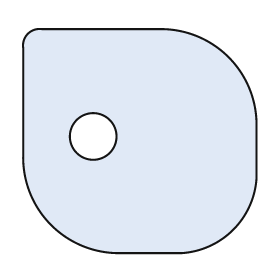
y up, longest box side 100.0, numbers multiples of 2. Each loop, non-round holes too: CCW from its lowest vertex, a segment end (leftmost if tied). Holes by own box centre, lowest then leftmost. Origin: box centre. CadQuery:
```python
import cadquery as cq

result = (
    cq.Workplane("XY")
    .moveTo(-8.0, -48.0)
    .lineTo(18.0, -48.0)
    .threePointArc((40.0, -38.0), (50.0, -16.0))
    .lineTo(50.0, 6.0)
    .threePointArc((38.0, 36.0), (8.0, 48.0))
    .lineTo(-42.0, 48.0)
    .threePointArc((-48.0, 46.0), (-50.0, 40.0))
    .lineTo(-50.0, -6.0)
    .threePointArc((-38.0, -36.0), (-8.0, -48.0))
    .close()
    .moveTo(-20.0, 2.0)
    .circle(10.0)
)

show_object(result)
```